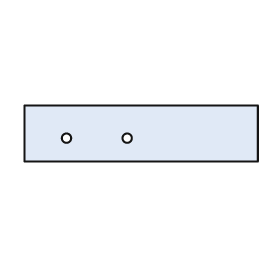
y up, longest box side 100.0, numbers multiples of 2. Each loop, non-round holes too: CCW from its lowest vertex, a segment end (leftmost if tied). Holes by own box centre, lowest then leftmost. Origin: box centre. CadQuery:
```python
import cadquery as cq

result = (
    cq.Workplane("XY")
    .moveTo(-50.0, -12.0)
    .lineTo(50.0, -12.0)
    .lineTo(50.0, 12.0)
    .lineTo(-50.0, 12.0)
    .close()
    .moveTo(-32.0, -2.0)
    .circle(2.0)
    .moveTo(-6.0, -2.0)
    .circle(2.0)
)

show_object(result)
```